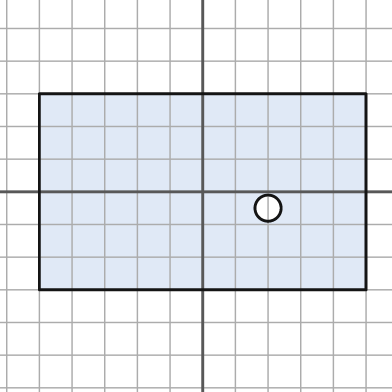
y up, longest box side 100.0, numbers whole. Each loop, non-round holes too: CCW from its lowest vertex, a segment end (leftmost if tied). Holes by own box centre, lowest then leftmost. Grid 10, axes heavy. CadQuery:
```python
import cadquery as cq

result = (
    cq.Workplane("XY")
    .moveTo(-50.0, -30.0)
    .lineTo(50.0, -30.0)
    .lineTo(50.0, 30.0)
    .lineTo(-50.0, 30.0)
    .close()
    .moveTo(20.0, -5.0)
    .circle(4.0)
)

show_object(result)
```